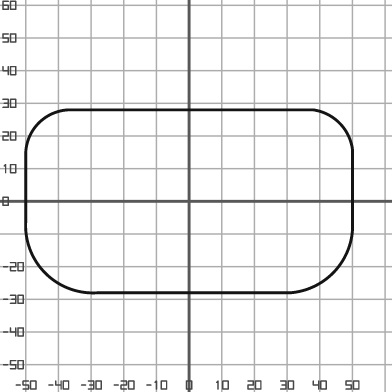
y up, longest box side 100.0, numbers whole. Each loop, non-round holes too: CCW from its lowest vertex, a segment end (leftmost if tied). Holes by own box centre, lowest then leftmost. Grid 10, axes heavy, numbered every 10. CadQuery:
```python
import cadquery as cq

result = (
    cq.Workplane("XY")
    .moveTo(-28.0, -28.0)
    .lineTo(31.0, -28.0)
    .threePointArc((44.0, -22.0), (50.0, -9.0))
    .lineTo(50.0, 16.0)
    .threePointArc((46.0, 24.0), (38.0, 28.0))
    .lineTo(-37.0, 28.0)
    .threePointArc((-46.0, 24.0), (-50.0, 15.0))
    .lineTo(-50.0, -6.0)
    .threePointArc((-44.0, -22.0), (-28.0, -28.0))
    .close()
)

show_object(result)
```